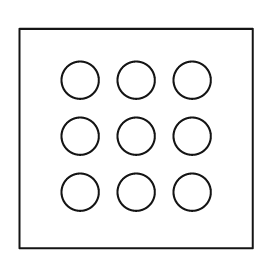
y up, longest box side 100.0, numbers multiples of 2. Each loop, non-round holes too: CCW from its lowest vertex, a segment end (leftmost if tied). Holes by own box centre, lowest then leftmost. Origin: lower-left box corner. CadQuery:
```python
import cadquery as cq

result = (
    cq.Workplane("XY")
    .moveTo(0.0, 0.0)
    .lineTo(100.0, 0.0)
    .lineTo(100.0, 94.0)
    .lineTo(0.0, 94.0)
    .close()
    .moveTo(26.0, 24.0)
    .circle(8.0)
    .moveTo(50.0, 24.0)
    .circle(8.0)
    .moveTo(74.0, 24.0)
    .circle(8.0)
    .moveTo(26.0, 48.0)
    .circle(8.0)
    .moveTo(50.0, 48.0)
    .circle(8.0)
    .moveTo(74.0, 48.0)
    .circle(8.0)
    .moveTo(26.0, 72.0)
    .circle(8.0)
    .moveTo(50.0, 72.0)
    .circle(8.0)
    .moveTo(74.0, 72.0)
    .circle(8.0)
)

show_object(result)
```